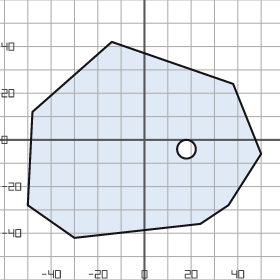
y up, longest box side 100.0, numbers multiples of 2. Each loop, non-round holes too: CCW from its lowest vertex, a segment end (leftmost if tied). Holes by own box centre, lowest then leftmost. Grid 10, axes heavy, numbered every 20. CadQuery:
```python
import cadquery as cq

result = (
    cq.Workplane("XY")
    .moveTo(-30.0, -42.0)
    .lineTo(24.0, -36.0)
    .lineTo(36.0, -28.0)
    .lineTo(50.0, -6.0)
    .lineTo(38.0, 24.0)
    .lineTo(-14.0, 42.0)
    .lineTo(-48.0, 12.0)
    .lineTo(-50.0, -28.0)
    .close()
    .moveTo(18.0, -4.0)
    .circle(4.0)
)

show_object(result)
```